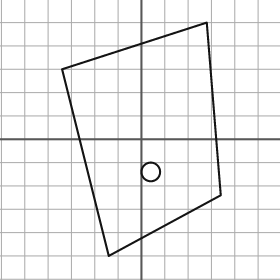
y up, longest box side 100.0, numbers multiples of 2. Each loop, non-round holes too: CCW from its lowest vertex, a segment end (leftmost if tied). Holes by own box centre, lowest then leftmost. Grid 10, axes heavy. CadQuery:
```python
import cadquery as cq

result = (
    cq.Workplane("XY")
    .moveTo(-14.0, -50.0)
    .lineTo(34.0, -24.0)
    .lineTo(28.0, 50.0)
    .lineTo(-34.0, 30.0)
    .close()
    .moveTo(4.0, -14.0)
    .circle(4.0)
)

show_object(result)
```